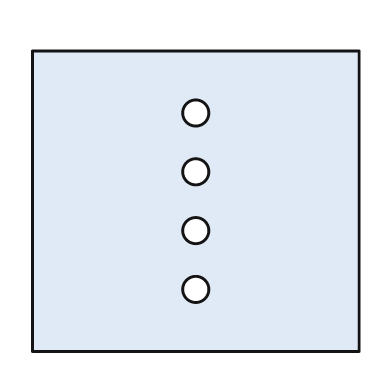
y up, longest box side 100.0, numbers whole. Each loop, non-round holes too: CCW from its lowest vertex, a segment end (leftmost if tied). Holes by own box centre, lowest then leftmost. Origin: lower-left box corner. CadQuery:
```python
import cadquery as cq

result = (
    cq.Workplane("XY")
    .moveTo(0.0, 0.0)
    .lineTo(100.0, 0.0)
    .lineTo(100.0, 92.0)
    .lineTo(0.0, 92.0)
    .close()
    .moveTo(50.0, 19.0)
    .circle(4.0)
    .moveTo(50.0, 37.0)
    .circle(4.0)
    .moveTo(50.0, 55.0)
    .circle(4.0)
    .moveTo(50.0, 73.0)
    .circle(4.0)
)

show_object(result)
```